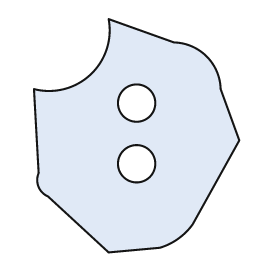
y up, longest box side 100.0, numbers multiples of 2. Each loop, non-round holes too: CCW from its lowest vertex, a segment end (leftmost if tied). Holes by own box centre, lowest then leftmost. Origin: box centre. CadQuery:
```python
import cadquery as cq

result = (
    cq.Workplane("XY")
    .moveTo(-12.0, -50.0)
    .lineTo(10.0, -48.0)
    .threePointArc((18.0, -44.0), (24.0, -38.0))
    .lineTo(44.0, -2.0)
    .lineTo(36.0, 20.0)
    .threePointArc((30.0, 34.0), (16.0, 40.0))
    .lineTo(-12.0, 50.0)
    .threePointArc((-20.0, 26.0), (-44.0, 20.0))
    .lineTo(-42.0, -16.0)
    .threePointArc((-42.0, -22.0), (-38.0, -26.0))
    .close()
    .moveTo(0.0, -12.0)
    .circle(8.0)
    .moveTo(0.0, 14.0)
    .circle(8.0)
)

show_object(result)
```